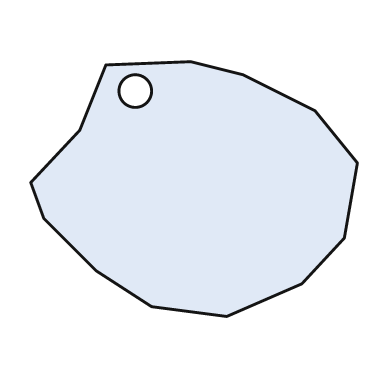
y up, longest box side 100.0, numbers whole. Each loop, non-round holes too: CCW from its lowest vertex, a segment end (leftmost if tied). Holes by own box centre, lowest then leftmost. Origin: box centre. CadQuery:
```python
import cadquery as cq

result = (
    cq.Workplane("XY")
    .moveTo(10.0, -39.0)
    .lineTo(33.0, -29.0)
    .lineTo(46.0, -15.0)
    .lineTo(50.0, 8.0)
    .lineTo(37.0, 24.0)
    .lineTo(15.0, 35.0)
    .lineTo(-1.0, 39.0)
    .lineTo(-27.0, 38.0)
    .lineTo(-35.0, 18.0)
    .lineTo(-50.0, 2.0)
    .lineTo(-46.0, -9.0)
    .lineTo(-30.0, -25.0)
    .lineTo(-13.0, -36.0)
    .close()
    .moveTo(-18.0, 30.0)
    .circle(5.0)
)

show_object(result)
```